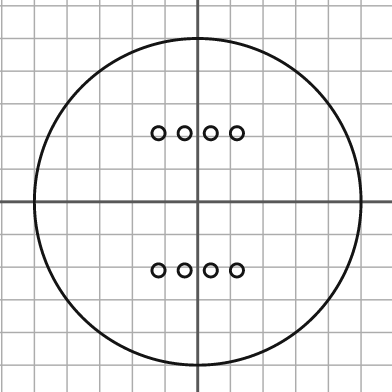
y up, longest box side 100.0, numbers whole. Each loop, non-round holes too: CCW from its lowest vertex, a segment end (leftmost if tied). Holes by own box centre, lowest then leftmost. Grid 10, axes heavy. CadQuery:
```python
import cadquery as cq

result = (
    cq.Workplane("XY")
    .moveTo(0.0, 0.0)
    .circle(50.0)
    .moveTo(-12.0, -21.0)
    .circle(2.0)
    .moveTo(-4.0, -21.0)
    .circle(2.0)
    .moveTo(4.0, -21.0)
    .circle(2.0)
    .moveTo(12.0, -21.0)
    .circle(2.0)
    .moveTo(-12.0, 21.0)
    .circle(2.0)
    .moveTo(-4.0, 21.0)
    .circle(2.0)
    .moveTo(4.0, 21.0)
    .circle(2.0)
    .moveTo(12.0, 21.0)
    .circle(2.0)
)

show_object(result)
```